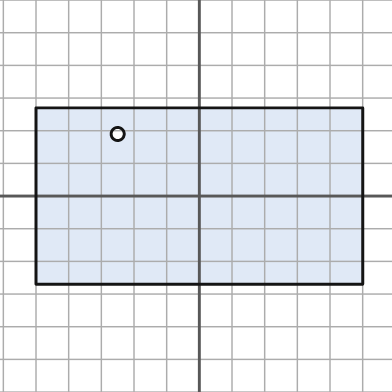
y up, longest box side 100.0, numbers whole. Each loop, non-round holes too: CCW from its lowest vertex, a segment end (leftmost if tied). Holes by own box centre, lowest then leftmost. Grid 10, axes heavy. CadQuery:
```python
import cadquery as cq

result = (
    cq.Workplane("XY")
    .moveTo(-50.0, -27.0)
    .lineTo(50.0, -27.0)
    .lineTo(50.0, 27.0)
    .lineTo(-50.0, 27.0)
    .close()
    .moveTo(-25.0, 19.0)
    .circle(2.0)
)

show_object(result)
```